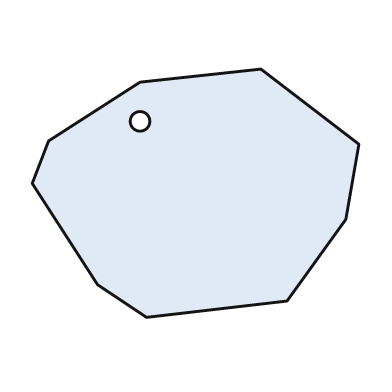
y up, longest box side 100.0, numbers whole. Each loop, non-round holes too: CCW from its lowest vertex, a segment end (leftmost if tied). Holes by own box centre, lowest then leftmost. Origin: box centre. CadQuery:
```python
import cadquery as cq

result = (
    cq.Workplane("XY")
    .moveTo(-15.0, -38.0)
    .lineTo(28.0, -33.0)
    .lineTo(46.0, -8.0)
    .lineTo(50.0, 15.0)
    .lineTo(20.0, 38.0)
    .lineTo(-17.0, 34.0)
    .lineTo(-45.0, 16.0)
    .lineTo(-50.0, 3.0)
    .lineTo(-30.0, -28.0)
    .close()
    .moveTo(-17.0, 22.0)
    .circle(3.0)
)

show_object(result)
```